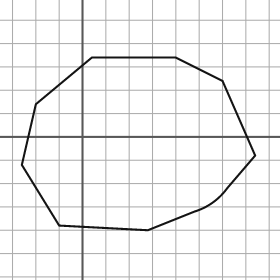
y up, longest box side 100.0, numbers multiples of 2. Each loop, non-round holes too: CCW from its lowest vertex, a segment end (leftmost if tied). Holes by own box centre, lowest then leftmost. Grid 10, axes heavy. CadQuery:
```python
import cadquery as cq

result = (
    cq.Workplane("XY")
    .moveTo(28.0, -40.0)
    .lineTo(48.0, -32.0)
    .threePointArc((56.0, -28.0), (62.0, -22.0))
    .lineTo(74.0, -8.0)
    .lineTo(60.0, 24.0)
    .lineTo(40.0, 34.0)
    .lineTo(4.0, 34.0)
    .lineTo(-20.0, 14.0)
    .lineTo(-26.0, -12.0)
    .lineTo(-10.0, -38.0)
    .close()
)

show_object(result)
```